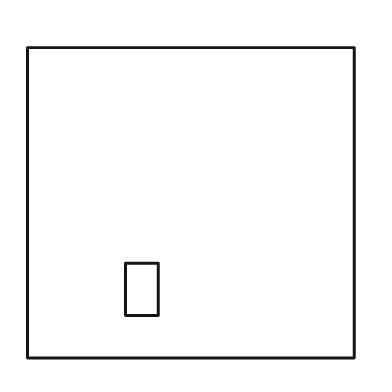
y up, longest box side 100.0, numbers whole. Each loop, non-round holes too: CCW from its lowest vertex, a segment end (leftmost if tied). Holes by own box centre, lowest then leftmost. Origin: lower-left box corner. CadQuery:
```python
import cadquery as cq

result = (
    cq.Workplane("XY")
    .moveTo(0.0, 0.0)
    .lineTo(100.0, 0.0)
    .lineTo(100.0, 95.0)
    .lineTo(0.0, 95.0)
    .close()
    .moveTo(30.0, 13.0)
    .lineTo(40.0, 13.0)
    .lineTo(40.0, 29.0)
    .lineTo(30.0, 29.0)
    .close()
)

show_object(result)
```